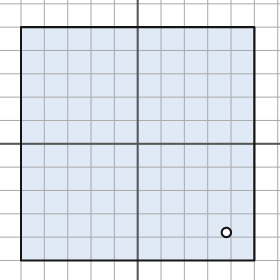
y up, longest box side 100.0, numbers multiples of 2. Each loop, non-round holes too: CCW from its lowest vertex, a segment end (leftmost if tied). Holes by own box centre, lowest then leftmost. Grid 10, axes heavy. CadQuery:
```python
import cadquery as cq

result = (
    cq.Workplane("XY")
    .moveTo(-50.0, -50.0)
    .lineTo(50.0, -50.0)
    .lineTo(50.0, 50.0)
    .lineTo(-50.0, 50.0)
    .close()
    .moveTo(38.0, -38.0)
    .circle(2.0)
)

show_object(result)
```